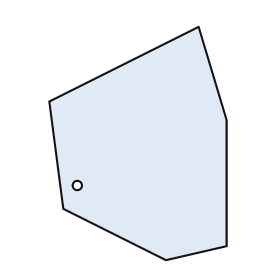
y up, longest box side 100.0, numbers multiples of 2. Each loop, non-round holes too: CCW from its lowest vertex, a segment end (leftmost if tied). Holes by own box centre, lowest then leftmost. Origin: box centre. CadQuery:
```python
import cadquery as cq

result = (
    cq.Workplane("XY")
    .moveTo(12.0, -50.0)
    .lineTo(38.0, -44.0)
    .lineTo(38.0, 10.0)
    .lineTo(26.0, 50.0)
    .lineTo(-38.0, 18.0)
    .lineTo(-32.0, -28.0)
    .close()
    .moveTo(-26.0, -18.0)
    .circle(2.0)
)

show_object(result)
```